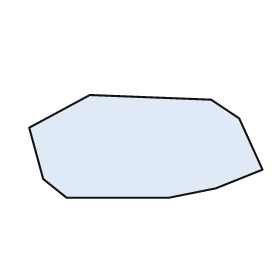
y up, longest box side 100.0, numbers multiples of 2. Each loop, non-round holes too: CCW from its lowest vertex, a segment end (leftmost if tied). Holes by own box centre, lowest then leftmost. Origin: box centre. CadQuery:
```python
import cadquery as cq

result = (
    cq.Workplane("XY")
    .moveTo(-34.0, -22.0)
    .lineTo(10.0, -22.0)
    .lineTo(30.0, -18.0)
    .lineTo(50.0, -10.0)
    .lineTo(40.0, 12.0)
    .lineTo(28.0, 20.0)
    .lineTo(-24.0, 22.0)
    .lineTo(-50.0, 8.0)
    .lineTo(-44.0, -14.0)
    .close()
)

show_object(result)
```